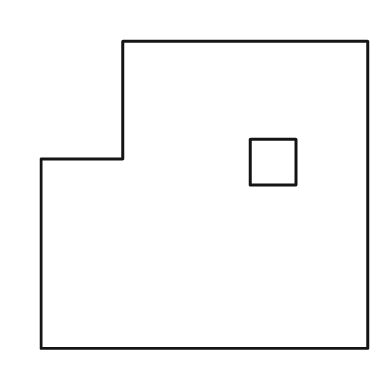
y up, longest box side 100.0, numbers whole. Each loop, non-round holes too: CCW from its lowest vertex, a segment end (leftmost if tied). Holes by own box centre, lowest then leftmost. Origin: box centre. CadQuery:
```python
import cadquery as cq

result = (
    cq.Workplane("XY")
    .moveTo(-50.0, -47.0)
    .lineTo(50.0, -47.0)
    .lineTo(50.0, 47.0)
    .lineTo(-25.0, 47.0)
    .lineTo(-25.0, 11.0)
    .lineTo(-50.0, 11.0)
    .close()
    .moveTo(14.0, 3.0)
    .lineTo(28.0, 3.0)
    .lineTo(28.0, 17.0)
    .lineTo(14.0, 17.0)
    .close()
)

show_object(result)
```